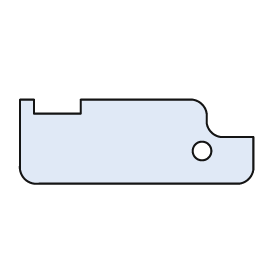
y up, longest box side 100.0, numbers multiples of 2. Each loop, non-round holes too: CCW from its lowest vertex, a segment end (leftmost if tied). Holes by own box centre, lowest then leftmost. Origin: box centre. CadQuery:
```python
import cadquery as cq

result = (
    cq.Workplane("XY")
    .moveTo(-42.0, -18.0)
    .lineTo(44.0, -18.0)
    .threePointArc((48.0, -16.0), (50.0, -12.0))
    .lineTo(50.0, 2.0)
    .lineTo(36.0, 2.0)
    .threePointArc((32.0, 4.0), (30.0, 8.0))
    .lineTo(30.0, 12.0)
    .threePointArc((28.0, 16.0), (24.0, 18.0))
    .lineTo(-24.0, 18.0)
    .lineTo(-24.0, 12.0)
    .lineTo(-44.0, 12.0)
    .lineTo(-44.0, 18.0)
    .lineTo(-50.0, 18.0)
    .lineTo(-50.0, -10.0)
    .threePointArc((-48.0, -16.0), (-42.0, -18.0))
    .close()
    .moveTo(28.0, -4.0)
    .circle(4.0)
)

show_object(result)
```